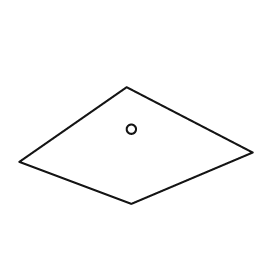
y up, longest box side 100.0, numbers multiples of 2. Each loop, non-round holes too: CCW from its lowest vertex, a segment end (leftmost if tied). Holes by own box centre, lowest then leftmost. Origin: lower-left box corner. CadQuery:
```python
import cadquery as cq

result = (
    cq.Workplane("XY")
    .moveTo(48.0, 0.0)
    .lineTo(100.0, 22.0)
    .lineTo(46.0, 50.0)
    .lineTo(0.0, 18.0)
    .close()
    .moveTo(48.0, 32.0)
    .circle(2.0)
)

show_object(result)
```